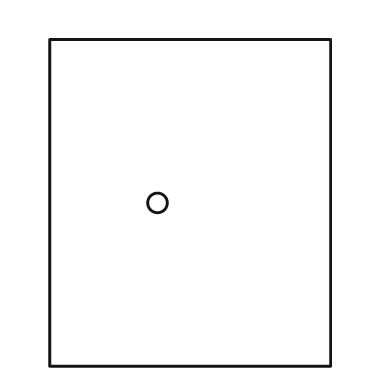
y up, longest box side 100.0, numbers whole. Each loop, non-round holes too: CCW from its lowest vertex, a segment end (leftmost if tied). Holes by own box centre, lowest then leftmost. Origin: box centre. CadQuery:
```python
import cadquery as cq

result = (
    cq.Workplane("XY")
    .moveTo(-43.0, -50.0)
    .lineTo(43.0, -50.0)
    .lineTo(43.0, 50.0)
    .lineTo(-43.0, 50.0)
    .close()
    .moveTo(-10.0, 0.0)
    .circle(3.0)
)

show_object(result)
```